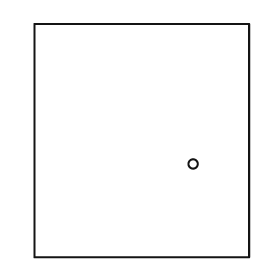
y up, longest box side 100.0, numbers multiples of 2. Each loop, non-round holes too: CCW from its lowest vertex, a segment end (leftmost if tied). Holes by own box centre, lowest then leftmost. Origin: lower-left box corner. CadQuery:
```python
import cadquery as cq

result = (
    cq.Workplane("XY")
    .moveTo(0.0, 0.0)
    .lineTo(92.0, 0.0)
    .lineTo(92.0, 100.0)
    .lineTo(0.0, 100.0)
    .close()
    .moveTo(68.0, 40.0)
    .circle(2.0)
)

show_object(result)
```